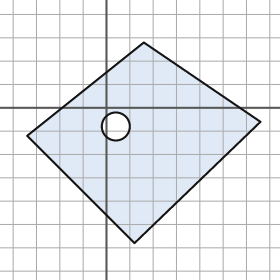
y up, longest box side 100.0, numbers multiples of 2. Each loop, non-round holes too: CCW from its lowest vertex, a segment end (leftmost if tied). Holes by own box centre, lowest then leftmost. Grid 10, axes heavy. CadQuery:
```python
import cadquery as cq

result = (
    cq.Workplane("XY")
    .moveTo(12.0, -58.0)
    .lineTo(66.0, -6.0)
    .lineTo(16.0, 28.0)
    .lineTo(-34.0, -12.0)
    .close()
    .moveTo(4.0, -8.0)
    .circle(6.0)
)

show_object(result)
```